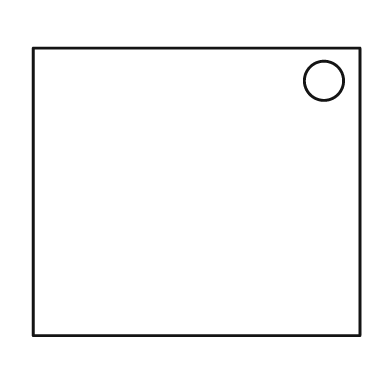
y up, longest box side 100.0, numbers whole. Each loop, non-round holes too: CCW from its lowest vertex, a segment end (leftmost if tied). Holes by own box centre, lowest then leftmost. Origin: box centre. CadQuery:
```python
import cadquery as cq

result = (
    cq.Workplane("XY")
    .moveTo(-50.0, -44.0)
    .lineTo(50.0, -44.0)
    .lineTo(50.0, 44.0)
    .lineTo(-50.0, 44.0)
    .close()
    .moveTo(39.0, 34.0)
    .circle(6.0)
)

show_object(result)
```